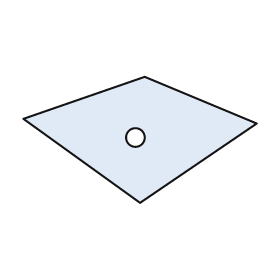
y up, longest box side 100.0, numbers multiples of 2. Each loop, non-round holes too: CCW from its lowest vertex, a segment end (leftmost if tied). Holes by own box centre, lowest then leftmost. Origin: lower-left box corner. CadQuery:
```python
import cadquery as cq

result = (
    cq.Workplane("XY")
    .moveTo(50.0, 0.0)
    .lineTo(100.0, 34.0)
    .lineTo(52.0, 54.0)
    .lineTo(0.0, 36.0)
    .close()
    .moveTo(48.0, 28.0)
    .circle(4.0)
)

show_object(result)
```